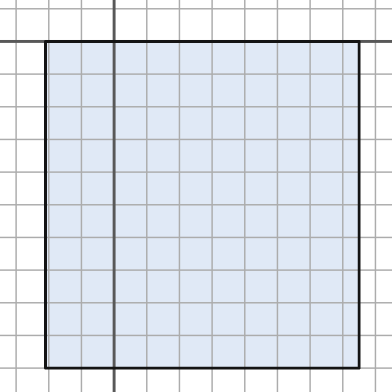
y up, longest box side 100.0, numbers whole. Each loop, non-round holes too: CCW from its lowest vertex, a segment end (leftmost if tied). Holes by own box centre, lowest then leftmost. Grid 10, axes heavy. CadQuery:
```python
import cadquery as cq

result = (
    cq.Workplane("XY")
    .moveTo(-21.0, -100.0)
    .lineTo(75.0, -100.0)
    .lineTo(75.0, 0.0)
    .lineTo(-21.0, 0.0)
    .close()
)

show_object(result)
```